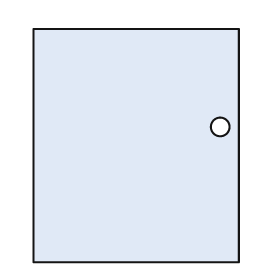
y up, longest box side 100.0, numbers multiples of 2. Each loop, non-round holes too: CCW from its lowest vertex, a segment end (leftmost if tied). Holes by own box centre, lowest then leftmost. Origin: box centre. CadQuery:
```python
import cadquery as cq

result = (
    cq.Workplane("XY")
    .moveTo(-44.0, -50.0)
    .lineTo(44.0, -50.0)
    .lineTo(44.0, 50.0)
    .lineTo(-44.0, 50.0)
    .close()
    .moveTo(36.0, 8.0)
    .circle(4.0)
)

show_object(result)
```